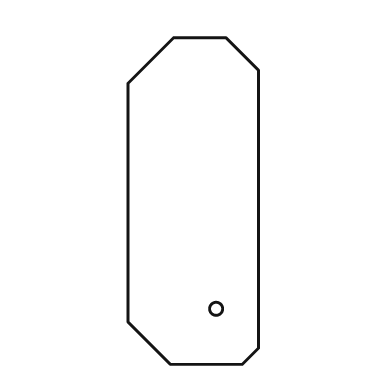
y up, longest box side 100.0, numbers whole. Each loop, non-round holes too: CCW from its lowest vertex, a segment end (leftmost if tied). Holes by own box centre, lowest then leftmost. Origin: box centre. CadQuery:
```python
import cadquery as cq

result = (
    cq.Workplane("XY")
    .moveTo(-7.0, -50.0)
    .lineTo(15.0, -50.0)
    .lineTo(20.0, -45.0)
    .lineTo(20.0, 40.0)
    .lineTo(10.0, 50.0)
    .lineTo(-6.0, 50.0)
    .lineTo(-20.0, 36.0)
    .lineTo(-20.0, -37.0)
    .close()
    .moveTo(7.0, -33.0)
    .circle(2.0)
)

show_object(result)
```